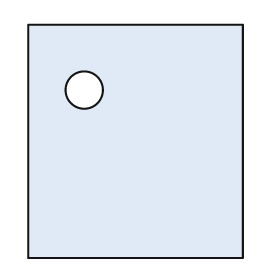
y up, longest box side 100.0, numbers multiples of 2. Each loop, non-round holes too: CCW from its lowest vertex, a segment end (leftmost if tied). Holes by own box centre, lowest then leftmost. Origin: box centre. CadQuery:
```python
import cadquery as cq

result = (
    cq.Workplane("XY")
    .moveTo(-46.0, -50.0)
    .lineTo(46.0, -50.0)
    .lineTo(46.0, 50.0)
    .lineTo(-46.0, 50.0)
    .close()
    .moveTo(-22.0, 22.0)
    .circle(8.0)
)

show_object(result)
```